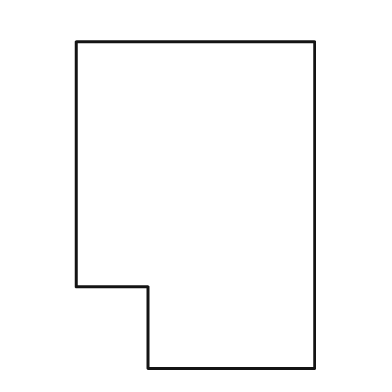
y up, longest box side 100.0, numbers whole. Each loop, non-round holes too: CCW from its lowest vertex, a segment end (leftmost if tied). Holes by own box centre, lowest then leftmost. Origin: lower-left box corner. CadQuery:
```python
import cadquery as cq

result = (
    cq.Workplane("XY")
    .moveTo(22.0, 0.0)
    .lineTo(73.0, 0.0)
    .lineTo(73.0, 100.0)
    .lineTo(0.0, 100.0)
    .lineTo(0.0, 25.0)
    .lineTo(22.0, 25.0)
    .close()
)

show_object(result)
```